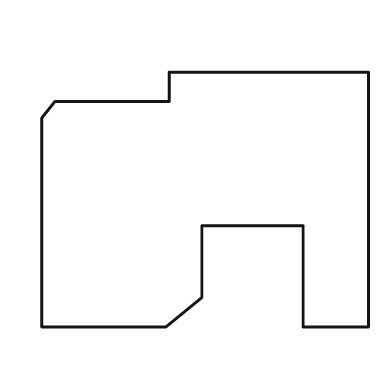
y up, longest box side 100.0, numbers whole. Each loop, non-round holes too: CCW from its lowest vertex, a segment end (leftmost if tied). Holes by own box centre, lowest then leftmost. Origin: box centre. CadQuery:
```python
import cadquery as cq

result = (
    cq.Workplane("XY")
    .moveTo(-50.0, -39.0)
    .lineTo(-12.0, -39.0)
    .lineTo(-1.0, -30.0)
    .lineTo(-1.0, -8.0)
    .lineTo(30.0, -8.0)
    .lineTo(30.0, -39.0)
    .lineTo(50.0, -39.0)
    .lineTo(50.0, 39.0)
    .lineTo(-11.0, 39.0)
    .lineTo(-11.0, 30.0)
    .lineTo(-46.0, 30.0)
    .lineTo(-50.0, 25.0)
    .close()
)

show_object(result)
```